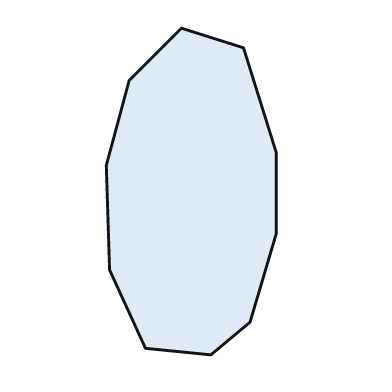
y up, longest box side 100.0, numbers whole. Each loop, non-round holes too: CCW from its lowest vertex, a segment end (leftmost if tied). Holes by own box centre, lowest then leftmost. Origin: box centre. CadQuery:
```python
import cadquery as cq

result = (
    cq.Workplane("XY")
    .moveTo(6.0, -50.0)
    .lineTo(18.0, -40.0)
    .lineTo(26.0, -13.0)
    .lineTo(26.0, 12.0)
    .lineTo(16.0, 44.0)
    .lineTo(-3.0, 50.0)
    .lineTo(-19.0, 34.0)
    .lineTo(-26.0, 8.0)
    .lineTo(-25.0, -24.0)
    .lineTo(-14.0, -48.0)
    .close()
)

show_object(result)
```